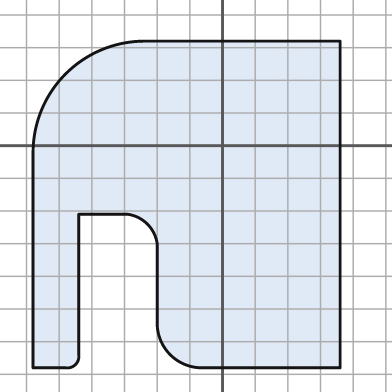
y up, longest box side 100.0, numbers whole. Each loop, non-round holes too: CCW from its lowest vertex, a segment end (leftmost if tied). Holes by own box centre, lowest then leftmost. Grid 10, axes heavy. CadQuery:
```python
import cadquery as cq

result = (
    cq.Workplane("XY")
    .moveTo(-58.0, -68.0)
    .lineTo(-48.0, -68.0)
    .threePointArc((-45.0, -67.0), (-44.0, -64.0))
    .lineTo(-44.0, -21.0)
    .lineTo(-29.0, -21.0)
    .threePointArc((-23.0, -24.0), (-20.0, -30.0))
    .lineTo(-20.0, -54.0)
    .threePointArc((-16.0, -64.0), (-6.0, -68.0))
    .lineTo(36.0, -68.0)
    .lineTo(36.0, 32.0)
    .lineTo(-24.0, 32.0)
    .threePointArc((-48.0, 22.0), (-58.0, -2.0))
    .close()
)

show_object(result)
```